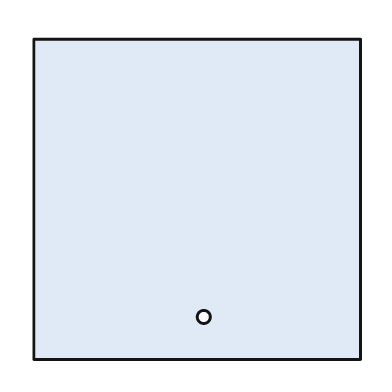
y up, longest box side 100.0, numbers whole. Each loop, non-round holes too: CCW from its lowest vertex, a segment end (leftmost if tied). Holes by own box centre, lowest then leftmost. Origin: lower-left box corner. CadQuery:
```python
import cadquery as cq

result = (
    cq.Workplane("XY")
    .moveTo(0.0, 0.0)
    .lineTo(100.0, 0.0)
    .lineTo(100.0, 98.0)
    .lineTo(0.0, 98.0)
    .close()
    .moveTo(52.0, 13.0)
    .circle(2.0)
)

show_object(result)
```